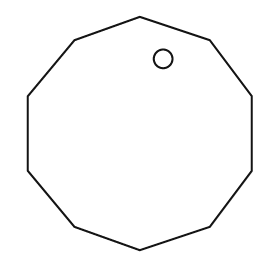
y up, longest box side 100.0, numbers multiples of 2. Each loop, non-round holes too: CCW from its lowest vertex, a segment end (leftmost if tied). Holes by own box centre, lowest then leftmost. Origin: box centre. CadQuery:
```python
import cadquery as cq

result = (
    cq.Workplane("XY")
    .moveTo(0.0, -50.0)
    .lineTo(30.0, -40.0)
    .lineTo(48.0, -16.0)
    .lineTo(48.0, 16.0)
    .lineTo(30.0, 40.0)
    .lineTo(0.0, 50.0)
    .lineTo(-28.0, 40.0)
    .lineTo(-48.0, 16.0)
    .lineTo(-48.0, -16.0)
    .lineTo(-28.0, -40.0)
    .close()
    .moveTo(10.0, 32.0)
    .circle(4.0)
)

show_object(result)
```